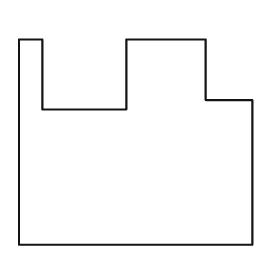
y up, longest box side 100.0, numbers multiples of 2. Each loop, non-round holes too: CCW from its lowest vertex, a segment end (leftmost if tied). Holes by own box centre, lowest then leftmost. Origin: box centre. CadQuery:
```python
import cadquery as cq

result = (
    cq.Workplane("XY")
    .moveTo(-50.0, -44.0)
    .lineTo(50.0, -44.0)
    .lineTo(50.0, 18.0)
    .lineTo(30.0, 18.0)
    .lineTo(30.0, 44.0)
    .lineTo(-4.0, 44.0)
    .lineTo(-4.0, 14.0)
    .lineTo(-40.0, 14.0)
    .lineTo(-40.0, 44.0)
    .lineTo(-50.0, 44.0)
    .close()
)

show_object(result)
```